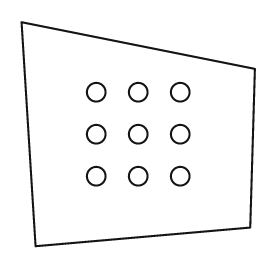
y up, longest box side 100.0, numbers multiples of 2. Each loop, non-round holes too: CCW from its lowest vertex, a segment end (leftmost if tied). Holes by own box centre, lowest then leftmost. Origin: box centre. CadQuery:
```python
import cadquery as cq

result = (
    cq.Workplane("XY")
    .moveTo(-44.0, -48.0)
    .lineTo(48.0, -40.0)
    .lineTo(50.0, 28.0)
    .lineTo(-50.0, 48.0)
    .close()
    .moveTo(-18.0, -18.0)
    .circle(4.0)
    .moveTo(0.0, -18.0)
    .circle(4.0)
    .moveTo(18.0, -18.0)
    .circle(4.0)
    .moveTo(-18.0, 0.0)
    .circle(4.0)
    .moveTo(0.0, 0.0)
    .circle(4.0)
    .moveTo(18.0, 0.0)
    .circle(4.0)
    .moveTo(-18.0, 18.0)
    .circle(4.0)
    .moveTo(0.0, 18.0)
    .circle(4.0)
    .moveTo(18.0, 18.0)
    .circle(4.0)
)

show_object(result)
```